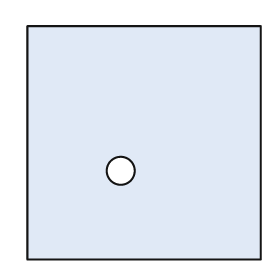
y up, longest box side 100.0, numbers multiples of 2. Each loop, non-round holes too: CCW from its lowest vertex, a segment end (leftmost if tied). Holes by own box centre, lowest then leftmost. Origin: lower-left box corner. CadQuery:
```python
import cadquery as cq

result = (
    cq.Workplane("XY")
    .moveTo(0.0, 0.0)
    .lineTo(100.0, 0.0)
    .lineTo(100.0, 100.0)
    .lineTo(0.0, 100.0)
    .close()
    .moveTo(40.0, 38.0)
    .circle(6.0)
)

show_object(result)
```